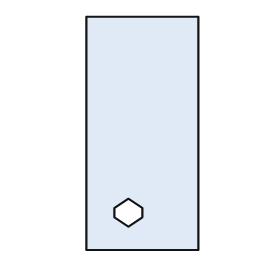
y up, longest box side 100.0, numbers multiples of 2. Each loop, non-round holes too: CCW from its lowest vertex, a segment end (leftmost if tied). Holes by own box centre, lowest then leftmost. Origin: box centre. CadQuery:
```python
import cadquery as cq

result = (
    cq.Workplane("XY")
    .moveTo(-24.0, -50.0)
    .lineTo(24.0, -50.0)
    .lineTo(24.0, 50.0)
    .lineTo(-24.0, 50.0)
    .close()
    .moveTo(-6.0, -40.0)
    .lineTo(0.0, -36.0)
    .lineTo(0.0, -32.0)
    .lineTo(-6.0, -28.0)
    .lineTo(-12.0, -32.0)
    .lineTo(-12.0, -36.0)
    .close()
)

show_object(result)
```